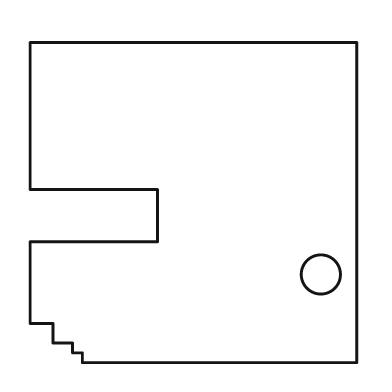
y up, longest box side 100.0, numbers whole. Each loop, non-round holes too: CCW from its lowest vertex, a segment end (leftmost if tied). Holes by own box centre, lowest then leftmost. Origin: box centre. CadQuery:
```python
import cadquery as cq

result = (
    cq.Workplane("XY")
    .moveTo(-34.0, -49.0)
    .lineTo(50.0, -49.0)
    .lineTo(50.0, 49.0)
    .lineTo(-50.0, 49.0)
    .lineTo(-50.0, 4.0)
    .lineTo(-11.0, 4.0)
    .lineTo(-11.0, -12.0)
    .lineTo(-50.0, -12.0)
    .lineTo(-50.0, -37.0)
    .lineTo(-43.0, -37.0)
    .lineTo(-43.0, -43.0)
    .lineTo(-37.0, -43.0)
    .lineTo(-37.0, -46.0)
    .lineTo(-34.0, -46.0)
    .close()
    .moveTo(39.0, -22.0)
    .circle(6.0)
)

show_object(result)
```